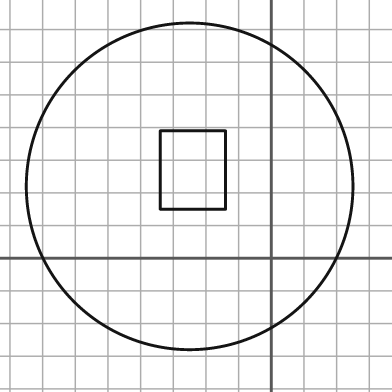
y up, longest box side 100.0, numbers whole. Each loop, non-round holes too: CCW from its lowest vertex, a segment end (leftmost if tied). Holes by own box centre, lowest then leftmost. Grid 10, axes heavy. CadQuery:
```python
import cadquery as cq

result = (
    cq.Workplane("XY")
    .moveTo(-25.0, 22.0)
    .circle(50.0)
    .moveTo(-34.0, 15.0)
    .lineTo(-14.0, 15.0)
    .lineTo(-14.0, 39.0)
    .lineTo(-34.0, 39.0)
    .close()
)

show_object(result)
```